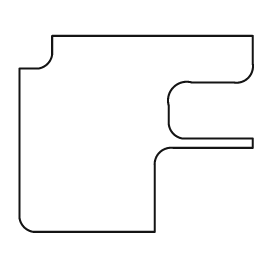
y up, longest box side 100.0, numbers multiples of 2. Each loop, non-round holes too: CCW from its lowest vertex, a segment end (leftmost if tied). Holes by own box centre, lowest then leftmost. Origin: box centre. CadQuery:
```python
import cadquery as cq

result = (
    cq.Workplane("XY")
    .moveTo(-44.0, -42.0)
    .lineTo(8.0, -42.0)
    .lineTo(8.0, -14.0)
    .threePointArc((10.0, -8.0), (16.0, -6.0))
    .lineTo(50.0, -6.0)
    .lineTo(50.0, -2.0)
    .lineTo(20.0, -2.0)
    .threePointArc((16.0, 0.0), (14.0, 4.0))
    .lineTo(14.0, 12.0)
    .threePointArc((16.0, 20.0), (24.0, 22.0))
    .lineTo(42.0, 22.0)
    .threePointArc((48.0, 24.0), (50.0, 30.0))
    .lineTo(50.0, 42.0)
    .lineTo(-36.0, 42.0)
    .lineTo(-36.0, 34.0)
    .threePointArc((-38.0, 30.0), (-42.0, 28.0))
    .lineTo(-50.0, 28.0)
    .lineTo(-50.0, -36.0)
    .threePointArc((-48.0, -40.0), (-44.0, -42.0))
    .close()
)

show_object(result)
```